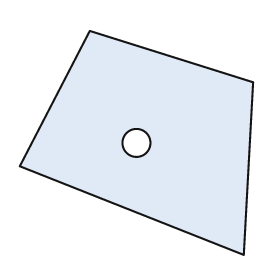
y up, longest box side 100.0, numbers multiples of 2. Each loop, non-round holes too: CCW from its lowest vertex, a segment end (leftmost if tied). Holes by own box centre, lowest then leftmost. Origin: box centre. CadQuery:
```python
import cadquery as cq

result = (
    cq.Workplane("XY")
    .moveTo(46.0, -48.0)
    .lineTo(50.0, 26.0)
    .lineTo(-20.0, 48.0)
    .lineTo(-50.0, -10.0)
    .close()
    .moveTo(0.0, 0.0)
    .circle(6.0)
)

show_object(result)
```